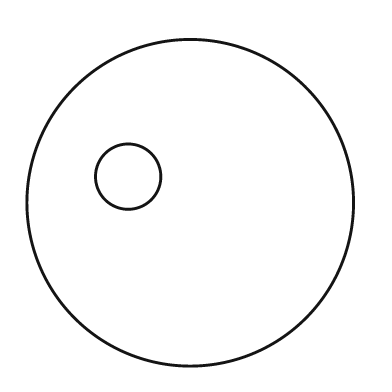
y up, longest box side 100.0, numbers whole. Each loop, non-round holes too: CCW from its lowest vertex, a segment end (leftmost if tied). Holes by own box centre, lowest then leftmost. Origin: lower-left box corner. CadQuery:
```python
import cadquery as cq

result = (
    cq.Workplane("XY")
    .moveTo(50.0, 50.0)
    .circle(50.0)
    .moveTo(31.0, 58.0)
    .circle(10.0)
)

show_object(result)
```